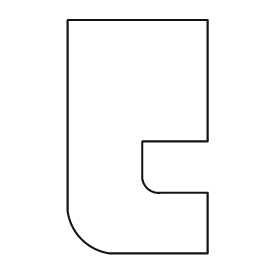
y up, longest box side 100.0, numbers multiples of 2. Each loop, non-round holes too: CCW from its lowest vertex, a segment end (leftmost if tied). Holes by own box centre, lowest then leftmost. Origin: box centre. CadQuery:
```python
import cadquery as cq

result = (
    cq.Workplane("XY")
    .moveTo(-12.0, -50.0)
    .lineTo(30.0, -50.0)
    .lineTo(30.0, -24.0)
    .lineTo(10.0, -24.0)
    .threePointArc((4.0, -22.0), (2.0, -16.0))
    .lineTo(2.0, -2.0)
    .lineTo(30.0, -2.0)
    .lineTo(30.0, 50.0)
    .lineTo(-30.0, 50.0)
    .lineTo(-30.0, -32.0)
    .threePointArc((-24.0, -44.0), (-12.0, -50.0))
    .close()
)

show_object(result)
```